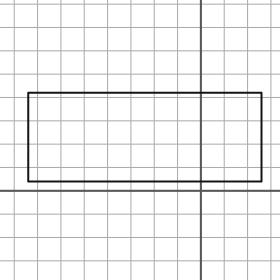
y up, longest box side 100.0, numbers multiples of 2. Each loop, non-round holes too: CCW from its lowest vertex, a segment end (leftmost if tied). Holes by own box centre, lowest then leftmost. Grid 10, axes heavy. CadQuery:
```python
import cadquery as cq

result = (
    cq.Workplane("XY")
    .moveTo(-74.0, 4.0)
    .lineTo(26.0, 4.0)
    .lineTo(26.0, 42.0)
    .lineTo(-74.0, 42.0)
    .close()
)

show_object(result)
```